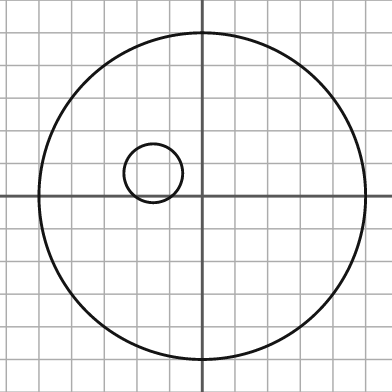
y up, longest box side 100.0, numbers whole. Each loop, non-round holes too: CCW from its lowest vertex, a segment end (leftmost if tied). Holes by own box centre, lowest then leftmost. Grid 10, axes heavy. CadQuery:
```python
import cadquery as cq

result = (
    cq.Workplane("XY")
    .moveTo(0.0, 0.0)
    .circle(50.0)
    .moveTo(-15.0, 7.0)
    .circle(9.0)
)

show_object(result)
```